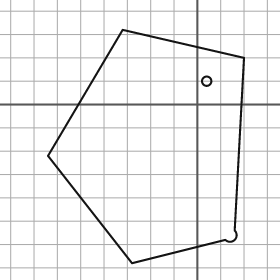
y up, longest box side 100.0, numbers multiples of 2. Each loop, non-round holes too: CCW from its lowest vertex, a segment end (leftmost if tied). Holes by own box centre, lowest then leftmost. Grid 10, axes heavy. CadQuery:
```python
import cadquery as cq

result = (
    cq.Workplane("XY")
    .moveTo(-28.0, -68.0)
    .lineTo(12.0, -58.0)
    .threePointArc((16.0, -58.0), (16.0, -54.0))
    .lineTo(20.0, 20.0)
    .lineTo(-32.0, 32.0)
    .lineTo(-64.0, -22.0)
    .close()
    .moveTo(4.0, 10.0)
    .circle(2.0)
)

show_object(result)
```